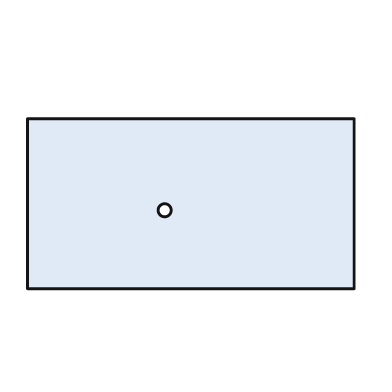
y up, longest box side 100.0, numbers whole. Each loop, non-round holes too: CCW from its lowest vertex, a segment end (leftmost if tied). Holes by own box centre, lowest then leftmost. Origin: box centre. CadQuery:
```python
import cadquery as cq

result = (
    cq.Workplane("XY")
    .moveTo(-50.0, -26.0)
    .lineTo(50.0, -26.0)
    .lineTo(50.0, 26.0)
    .lineTo(-50.0, 26.0)
    .close()
    .moveTo(-8.0, -2.0)
    .circle(2.0)
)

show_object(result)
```